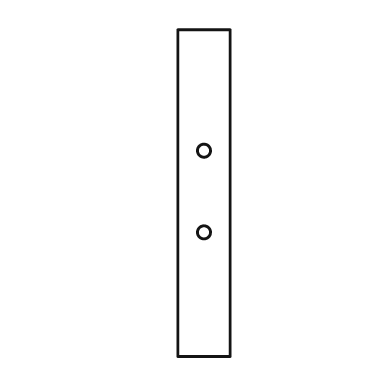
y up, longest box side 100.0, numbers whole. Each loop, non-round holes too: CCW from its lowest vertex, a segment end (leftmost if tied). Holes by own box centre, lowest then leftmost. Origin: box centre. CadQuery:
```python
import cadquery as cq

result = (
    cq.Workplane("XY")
    .moveTo(-8.0, -50.0)
    .lineTo(8.0, -50.0)
    .lineTo(8.0, 50.0)
    .lineTo(-8.0, 50.0)
    .close()
    .moveTo(0.0, -12.0)
    .circle(2.0)
    .moveTo(0.0, 13.0)
    .circle(2.0)
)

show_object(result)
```